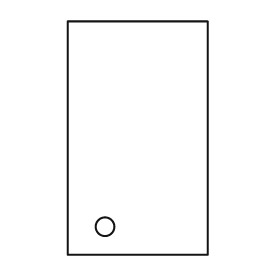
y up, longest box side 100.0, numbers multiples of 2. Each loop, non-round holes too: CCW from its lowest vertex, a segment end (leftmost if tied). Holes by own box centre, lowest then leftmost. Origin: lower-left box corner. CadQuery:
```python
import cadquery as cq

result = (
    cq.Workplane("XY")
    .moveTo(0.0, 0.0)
    .lineTo(60.0, 0.0)
    .lineTo(60.0, 100.0)
    .lineTo(0.0, 100.0)
    .close()
    .moveTo(16.0, 12.0)
    .circle(4.0)
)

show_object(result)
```